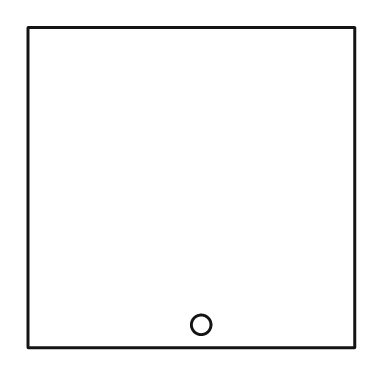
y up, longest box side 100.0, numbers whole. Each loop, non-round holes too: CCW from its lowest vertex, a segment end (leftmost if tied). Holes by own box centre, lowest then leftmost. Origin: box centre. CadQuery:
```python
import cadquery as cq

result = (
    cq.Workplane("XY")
    .moveTo(-50.0, -49.0)
    .lineTo(50.0, -49.0)
    .lineTo(50.0, 49.0)
    .lineTo(-50.0, 49.0)
    .close()
    .moveTo(3.0, -42.0)
    .circle(3.0)
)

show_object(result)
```